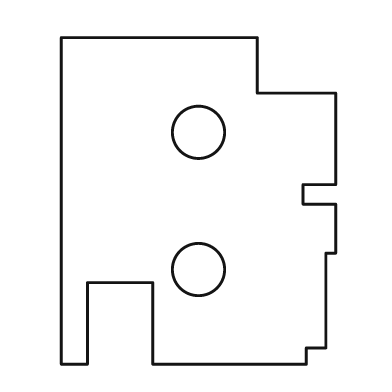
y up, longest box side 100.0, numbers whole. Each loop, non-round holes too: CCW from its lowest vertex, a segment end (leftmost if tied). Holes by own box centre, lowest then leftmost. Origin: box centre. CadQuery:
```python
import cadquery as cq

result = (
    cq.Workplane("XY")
    .moveTo(-42.0, -50.0)
    .lineTo(-34.0, -50.0)
    .lineTo(-34.0, -25.0)
    .lineTo(-14.0, -25.0)
    .lineTo(-14.0, -50.0)
    .lineTo(33.0, -50.0)
    .lineTo(33.0, -45.0)
    .lineTo(39.0, -45.0)
    .lineTo(39.0, -16.0)
    .lineTo(42.0, -16.0)
    .lineTo(42.0, -1.0)
    .lineTo(32.0, -1.0)
    .lineTo(32.0, 5.0)
    .lineTo(42.0, 5.0)
    .lineTo(42.0, 33.0)
    .lineTo(18.0, 33.0)
    .lineTo(18.0, 50.0)
    .lineTo(-42.0, 50.0)
    .close()
    .moveTo(0.0, -21.0)
    .circle(8.0)
    .moveTo(0.0, 21.0)
    .circle(8.0)
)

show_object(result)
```